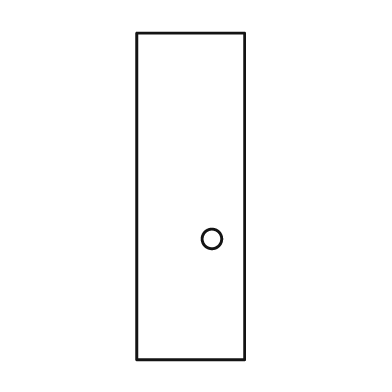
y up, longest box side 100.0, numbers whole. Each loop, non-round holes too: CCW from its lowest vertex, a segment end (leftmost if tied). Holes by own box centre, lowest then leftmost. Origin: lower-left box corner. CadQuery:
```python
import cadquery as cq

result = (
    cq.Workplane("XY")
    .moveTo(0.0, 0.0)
    .lineTo(33.0, 0.0)
    .lineTo(33.0, 100.0)
    .lineTo(0.0, 100.0)
    .close()
    .moveTo(23.0, 37.0)
    .circle(3.0)
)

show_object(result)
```